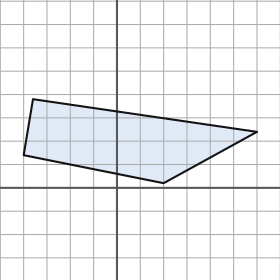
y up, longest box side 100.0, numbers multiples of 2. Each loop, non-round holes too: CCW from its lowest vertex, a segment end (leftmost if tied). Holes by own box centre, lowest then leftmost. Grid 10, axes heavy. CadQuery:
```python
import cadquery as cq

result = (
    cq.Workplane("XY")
    .moveTo(20.0, 2.0)
    .lineTo(60.0, 24.0)
    .lineTo(-36.0, 38.0)
    .lineTo(-40.0, 14.0)
    .close()
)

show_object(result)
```